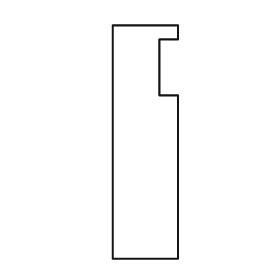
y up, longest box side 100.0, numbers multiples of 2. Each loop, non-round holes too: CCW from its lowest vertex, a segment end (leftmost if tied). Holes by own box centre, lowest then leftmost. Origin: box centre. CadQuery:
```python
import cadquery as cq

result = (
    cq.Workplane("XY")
    .moveTo(-14.0, -50.0)
    .lineTo(14.0, -50.0)
    .lineTo(14.0, 20.0)
    .lineTo(6.0, 20.0)
    .lineTo(6.0, 44.0)
    .lineTo(14.0, 44.0)
    .lineTo(14.0, 50.0)
    .lineTo(-14.0, 50.0)
    .close()
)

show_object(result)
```